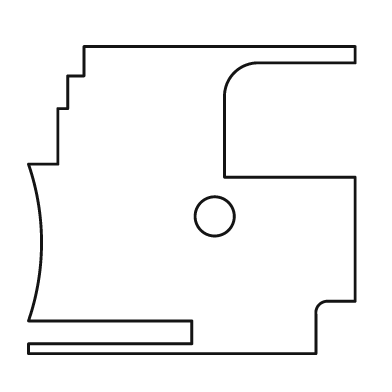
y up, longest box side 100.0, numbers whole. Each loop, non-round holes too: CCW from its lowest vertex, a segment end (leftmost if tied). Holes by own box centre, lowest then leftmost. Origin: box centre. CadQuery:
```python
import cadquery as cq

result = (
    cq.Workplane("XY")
    .moveTo(-50.0, -47.0)
    .lineTo(38.0, -47.0)
    .lineTo(38.0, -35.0)
    .threePointArc((39.0, -32.0), (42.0, -31.0))
    .lineTo(50.0, -31.0)
    .lineTo(50.0, 7.0)
    .lineTo(10.0, 7.0)
    .lineTo(10.0, 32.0)
    .threePointArc((13.0, 39.0), (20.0, 42.0))
    .lineTo(50.0, 42.0)
    .lineTo(50.0, 47.0)
    .lineTo(-33.0, 47.0)
    .lineTo(-33.0, 38.0)
    .lineTo(-38.0, 38.0)
    .lineTo(-38.0, 28.0)
    .lineTo(-41.0, 28.0)
    .lineTo(-41.0, 11.0)
    .lineTo(-50.0, 11.0)
    .threePointArc((-46.0, -13.0), (-50.0, -37.0))
    .lineTo(0.0, -37.0)
    .lineTo(0.0, -44.0)
    .lineTo(-50.0, -44.0)
    .close()
    .moveTo(7.0, -5.0)
    .circle(6.0)
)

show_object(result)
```